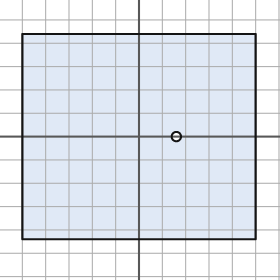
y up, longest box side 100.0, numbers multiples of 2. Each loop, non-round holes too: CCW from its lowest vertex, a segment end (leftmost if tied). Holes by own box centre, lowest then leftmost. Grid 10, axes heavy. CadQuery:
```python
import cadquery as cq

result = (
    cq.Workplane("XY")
    .moveTo(-50.0, -44.0)
    .lineTo(50.0, -44.0)
    .lineTo(50.0, 44.0)
    .lineTo(-50.0, 44.0)
    .close()
    .moveTo(16.0, 0.0)
    .circle(2.0)
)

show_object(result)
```